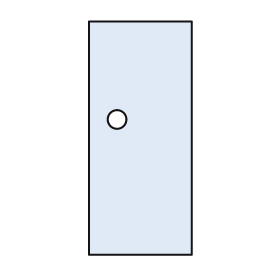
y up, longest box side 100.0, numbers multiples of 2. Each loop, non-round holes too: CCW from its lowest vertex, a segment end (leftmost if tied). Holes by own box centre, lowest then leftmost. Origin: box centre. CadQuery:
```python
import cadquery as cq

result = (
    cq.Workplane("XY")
    .moveTo(-22.0, -50.0)
    .lineTo(22.0, -50.0)
    .lineTo(22.0, 50.0)
    .lineTo(-22.0, 50.0)
    .close()
    .moveTo(-10.0, 8.0)
    .circle(4.0)
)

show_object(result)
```